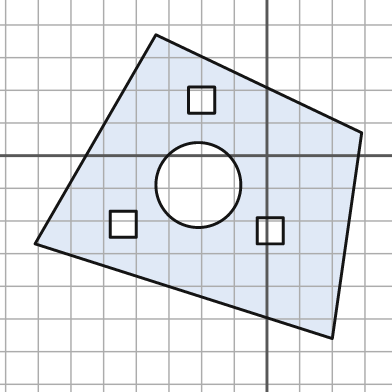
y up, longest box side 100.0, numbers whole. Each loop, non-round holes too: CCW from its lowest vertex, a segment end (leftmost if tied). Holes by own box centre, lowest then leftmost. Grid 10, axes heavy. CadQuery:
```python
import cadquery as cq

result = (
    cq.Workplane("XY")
    .moveTo(20.0, -56.0)
    .lineTo(29.0, 7.0)
    .lineTo(-34.0, 37.0)
    .lineTo(-71.0, -27.0)
    .close()
    .moveTo(-3.0, -27.0)
    .lineTo(5.0, -27.0)
    .lineTo(5.0, -19.0)
    .lineTo(-3.0, -19.0)
    .close()
    .moveTo(-48.0, -25.0)
    .lineTo(-40.0, -25.0)
    .lineTo(-40.0, -17.0)
    .lineTo(-48.0, -17.0)
    .close()
    .moveTo(-21.0, -9.0)
    .circle(13.0)
    .moveTo(-24.0, 13.0)
    .lineTo(-16.0, 13.0)
    .lineTo(-16.0, 21.0)
    .lineTo(-24.0, 21.0)
    .close()
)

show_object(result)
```